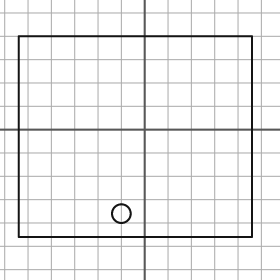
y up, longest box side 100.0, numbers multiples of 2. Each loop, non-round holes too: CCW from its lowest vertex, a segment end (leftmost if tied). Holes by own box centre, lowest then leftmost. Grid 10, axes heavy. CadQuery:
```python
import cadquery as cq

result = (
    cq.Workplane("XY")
    .moveTo(-54.0, -46.0)
    .lineTo(46.0, -46.0)
    .lineTo(46.0, 40.0)
    .lineTo(-54.0, 40.0)
    .close()
    .moveTo(-10.0, -36.0)
    .circle(4.0)
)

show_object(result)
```